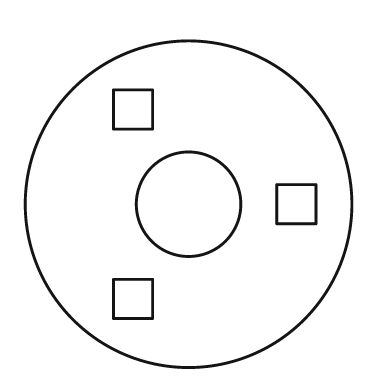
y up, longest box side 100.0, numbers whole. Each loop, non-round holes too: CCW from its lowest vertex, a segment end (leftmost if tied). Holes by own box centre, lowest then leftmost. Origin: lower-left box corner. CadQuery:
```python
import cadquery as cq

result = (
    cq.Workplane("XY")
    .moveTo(50.0, 50.0)
    .circle(50.0)
    .moveTo(27.0, 15.0)
    .lineTo(39.0, 15.0)
    .lineTo(39.0, 27.0)
    .lineTo(27.0, 27.0)
    .close()
    .moveTo(50.0, 50.0)
    .circle(16.0)
    .moveTo(77.0, 44.0)
    .lineTo(89.0, 44.0)
    .lineTo(89.0, 56.0)
    .lineTo(77.0, 56.0)
    .close()
    .moveTo(27.0, 73.0)
    .lineTo(39.0, 73.0)
    .lineTo(39.0, 85.0)
    .lineTo(27.0, 85.0)
    .close()
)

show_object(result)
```